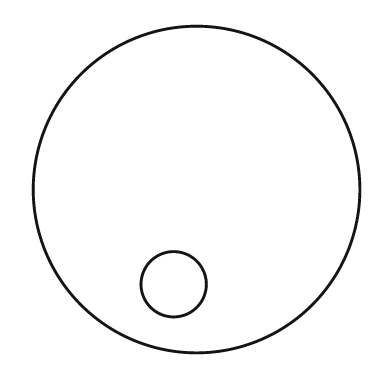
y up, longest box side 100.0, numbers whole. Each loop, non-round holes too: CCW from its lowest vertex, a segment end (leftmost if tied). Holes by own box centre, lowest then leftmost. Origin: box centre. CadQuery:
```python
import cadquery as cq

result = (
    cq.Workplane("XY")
    .moveTo(0.0, 0.0)
    .circle(50.0)
    .moveTo(-7.0, -29.0)
    .circle(10.0)
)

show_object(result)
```